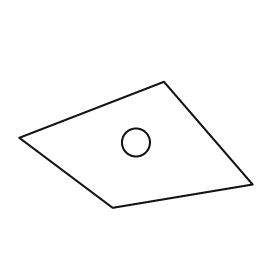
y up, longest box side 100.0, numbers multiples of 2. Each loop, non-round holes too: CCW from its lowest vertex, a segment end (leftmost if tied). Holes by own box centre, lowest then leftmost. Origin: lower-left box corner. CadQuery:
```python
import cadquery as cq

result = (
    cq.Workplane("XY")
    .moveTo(40.0, 0.0)
    .lineTo(100.0, 10.0)
    .lineTo(62.0, 54.0)
    .lineTo(0.0, 30.0)
    .close()
    .moveTo(50.0, 28.0)
    .circle(6.0)
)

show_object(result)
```